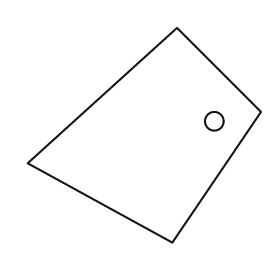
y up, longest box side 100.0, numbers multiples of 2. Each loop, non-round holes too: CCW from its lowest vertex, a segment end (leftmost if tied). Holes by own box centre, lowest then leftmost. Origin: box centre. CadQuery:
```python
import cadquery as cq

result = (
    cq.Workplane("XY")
    .moveTo(12.0, -46.0)
    .lineTo(50.0, 10.0)
    .lineTo(14.0, 46.0)
    .lineTo(-50.0, -12.0)
    .close()
    .moveTo(30.0, 6.0)
    .circle(4.0)
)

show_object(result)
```